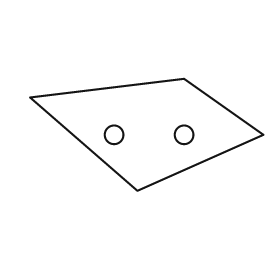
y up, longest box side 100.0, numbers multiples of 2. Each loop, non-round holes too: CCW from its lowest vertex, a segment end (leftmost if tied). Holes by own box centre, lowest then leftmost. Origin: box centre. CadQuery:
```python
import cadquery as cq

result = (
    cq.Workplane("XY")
    .moveTo(-4.0, -24.0)
    .lineTo(50.0, 0.0)
    .lineTo(16.0, 24.0)
    .lineTo(-50.0, 16.0)
    .close()
    .moveTo(-14.0, 0.0)
    .circle(4.0)
    .moveTo(16.0, 0.0)
    .circle(4.0)
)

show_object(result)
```